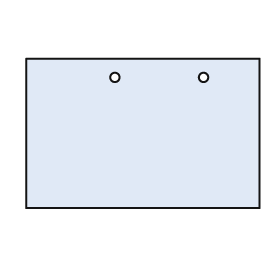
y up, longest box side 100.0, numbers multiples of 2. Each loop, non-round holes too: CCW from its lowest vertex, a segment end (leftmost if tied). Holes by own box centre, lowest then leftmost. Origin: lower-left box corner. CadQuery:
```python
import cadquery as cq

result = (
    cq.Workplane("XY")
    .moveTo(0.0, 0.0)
    .lineTo(100.0, 0.0)
    .lineTo(100.0, 64.0)
    .lineTo(0.0, 64.0)
    .close()
    .moveTo(38.0, 56.0)
    .circle(2.0)
    .moveTo(76.0, 56.0)
    .circle(2.0)
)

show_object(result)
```